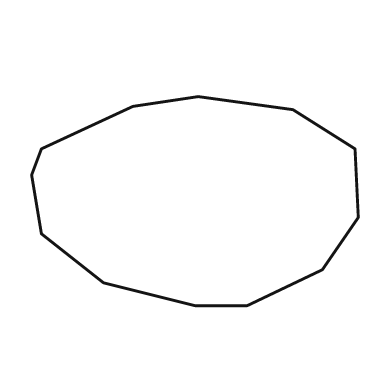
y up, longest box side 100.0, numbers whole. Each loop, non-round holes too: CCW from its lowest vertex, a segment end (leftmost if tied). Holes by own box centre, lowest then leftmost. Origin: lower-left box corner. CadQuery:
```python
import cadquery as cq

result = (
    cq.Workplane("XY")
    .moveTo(50.0, 0.0)
    .lineTo(66.0, 0.0)
    .lineTo(89.0, 11.0)
    .lineTo(100.0, 27.0)
    .lineTo(99.0, 48.0)
    .lineTo(80.0, 60.0)
    .lineTo(51.0, 64.0)
    .lineTo(31.0, 61.0)
    .lineTo(3.0, 48.0)
    .lineTo(0.0, 40.0)
    .lineTo(3.0, 22.0)
    .lineTo(22.0, 7.0)
    .close()
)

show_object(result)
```